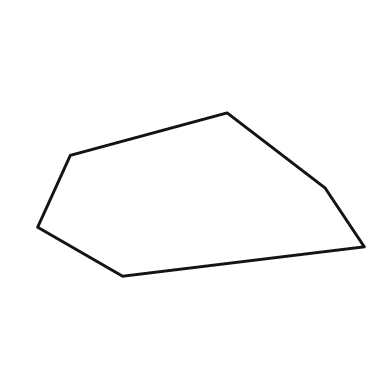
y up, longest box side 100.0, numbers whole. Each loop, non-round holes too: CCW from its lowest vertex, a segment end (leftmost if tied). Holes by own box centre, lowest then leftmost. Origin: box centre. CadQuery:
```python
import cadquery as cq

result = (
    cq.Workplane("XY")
    .moveTo(-24.0, -25.0)
    .lineTo(50.0, -16.0)
    .lineTo(38.0, 2.0)
    .lineTo(8.0, 25.0)
    .lineTo(-40.0, 12.0)
    .lineTo(-50.0, -10.0)
    .close()
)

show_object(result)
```